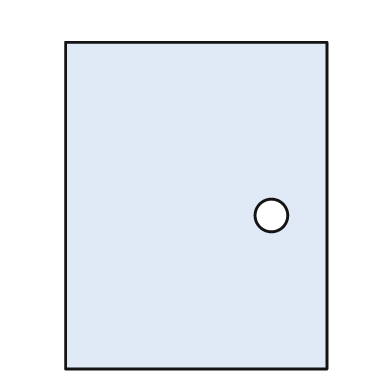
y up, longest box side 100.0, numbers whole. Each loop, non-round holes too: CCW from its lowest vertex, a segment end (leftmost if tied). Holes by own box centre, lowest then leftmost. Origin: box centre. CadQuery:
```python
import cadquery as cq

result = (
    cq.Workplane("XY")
    .moveTo(-40.0, -50.0)
    .lineTo(40.0, -50.0)
    .lineTo(40.0, 50.0)
    .lineTo(-40.0, 50.0)
    .close()
    .moveTo(23.0, -3.0)
    .circle(5.0)
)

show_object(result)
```